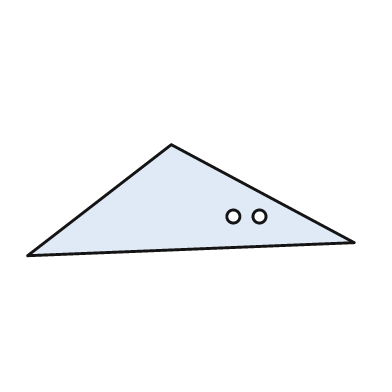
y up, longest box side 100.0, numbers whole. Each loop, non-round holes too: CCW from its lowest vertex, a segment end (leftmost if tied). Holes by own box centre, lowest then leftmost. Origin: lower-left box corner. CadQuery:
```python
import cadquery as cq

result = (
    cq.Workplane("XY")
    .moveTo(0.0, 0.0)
    .lineTo(100.0, 4.0)
    .lineTo(44.0, 34.0)
    .close()
    .moveTo(63.0, 12.0)
    .circle(2.0)
    .moveTo(71.0, 12.0)
    .circle(2.0)
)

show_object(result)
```